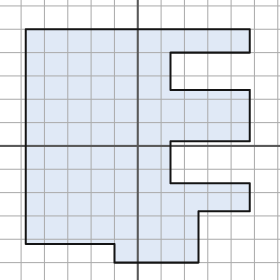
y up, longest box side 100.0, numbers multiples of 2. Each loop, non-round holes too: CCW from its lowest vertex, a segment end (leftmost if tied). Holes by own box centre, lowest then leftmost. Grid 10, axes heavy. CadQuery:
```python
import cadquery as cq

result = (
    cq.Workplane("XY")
    .moveTo(-10.0, -50.0)
    .lineTo(26.0, -50.0)
    .lineTo(26.0, -28.0)
    .lineTo(48.0, -28.0)
    .lineTo(48.0, -16.0)
    .lineTo(14.0, -16.0)
    .lineTo(14.0, 2.0)
    .lineTo(48.0, 2.0)
    .lineTo(48.0, 24.0)
    .lineTo(14.0, 24.0)
    .lineTo(14.0, 40.0)
    .lineTo(48.0, 40.0)
    .lineTo(48.0, 50.0)
    .lineTo(-48.0, 50.0)
    .lineTo(-48.0, -42.0)
    .lineTo(-10.0, -42.0)
    .close()
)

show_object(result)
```